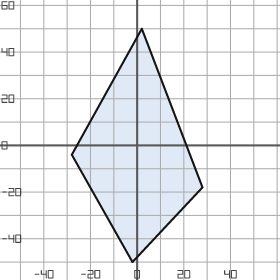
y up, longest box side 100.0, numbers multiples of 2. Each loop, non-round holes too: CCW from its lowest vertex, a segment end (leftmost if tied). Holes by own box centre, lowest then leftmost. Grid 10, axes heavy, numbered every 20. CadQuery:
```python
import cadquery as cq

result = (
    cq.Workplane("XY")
    .moveTo(-2.0, -50.0)
    .lineTo(28.0, -18.0)
    .lineTo(2.0, 50.0)
    .lineTo(-28.0, -4.0)
    .close()
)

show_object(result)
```